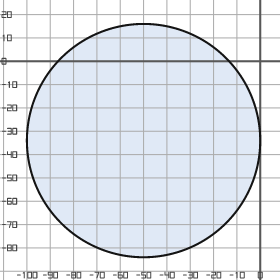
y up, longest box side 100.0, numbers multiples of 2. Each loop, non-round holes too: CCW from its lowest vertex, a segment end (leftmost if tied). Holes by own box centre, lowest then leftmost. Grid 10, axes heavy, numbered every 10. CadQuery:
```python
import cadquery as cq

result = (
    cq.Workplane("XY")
    .moveTo(-50.0, -34.0)
    .circle(50.0)
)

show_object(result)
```